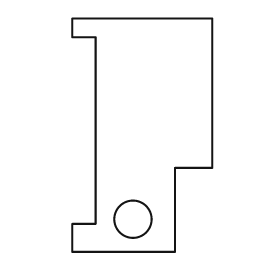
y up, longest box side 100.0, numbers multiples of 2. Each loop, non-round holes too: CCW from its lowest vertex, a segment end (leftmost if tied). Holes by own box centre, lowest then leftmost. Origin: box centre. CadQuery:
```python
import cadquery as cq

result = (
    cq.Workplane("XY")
    .moveTo(-30.0, -50.0)
    .lineTo(14.0, -50.0)
    .lineTo(14.0, -14.0)
    .lineTo(30.0, -14.0)
    .lineTo(30.0, 50.0)
    .lineTo(-30.0, 50.0)
    .lineTo(-30.0, 42.0)
    .lineTo(-20.0, 42.0)
    .lineTo(-20.0, -38.0)
    .lineTo(-30.0, -38.0)
    .close()
    .moveTo(-4.0, -36.0)
    .circle(8.0)
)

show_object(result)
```